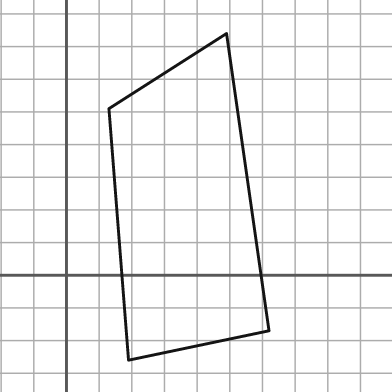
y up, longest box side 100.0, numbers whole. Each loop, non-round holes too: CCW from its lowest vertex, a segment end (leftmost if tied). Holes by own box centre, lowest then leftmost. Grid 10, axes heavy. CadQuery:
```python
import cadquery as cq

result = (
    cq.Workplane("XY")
    .moveTo(19.0, -26.0)
    .lineTo(62.0, -17.0)
    .lineTo(49.0, 74.0)
    .lineTo(13.0, 51.0)
    .close()
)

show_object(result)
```